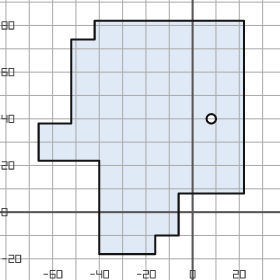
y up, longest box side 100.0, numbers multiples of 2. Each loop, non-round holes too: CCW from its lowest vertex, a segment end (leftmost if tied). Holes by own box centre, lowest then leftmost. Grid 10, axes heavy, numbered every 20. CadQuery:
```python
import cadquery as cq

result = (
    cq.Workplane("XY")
    .moveTo(-40.0, -18.0)
    .lineTo(-16.0, -18.0)
    .lineTo(-16.0, -10.0)
    .lineTo(-6.0, -10.0)
    .lineTo(-6.0, 8.0)
    .lineTo(22.0, 8.0)
    .lineTo(22.0, 82.0)
    .lineTo(-42.0, 82.0)
    .lineTo(-42.0, 74.0)
    .lineTo(-52.0, 74.0)
    .lineTo(-52.0, 38.0)
    .lineTo(-66.0, 38.0)
    .lineTo(-66.0, 22.0)
    .lineTo(-40.0, 22.0)
    .close()
    .moveTo(8.0, 40.0)
    .circle(2.0)
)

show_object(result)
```